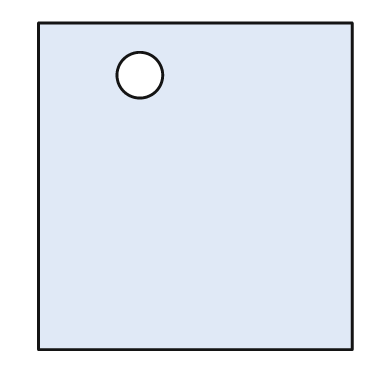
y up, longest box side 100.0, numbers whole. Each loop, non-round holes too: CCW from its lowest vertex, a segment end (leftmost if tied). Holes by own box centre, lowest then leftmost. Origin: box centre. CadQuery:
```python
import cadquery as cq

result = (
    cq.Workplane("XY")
    .moveTo(-48.0, -50.0)
    .lineTo(48.0, -50.0)
    .lineTo(48.0, 50.0)
    .lineTo(-48.0, 50.0)
    .close()
    .moveTo(-17.0, 34.0)
    .circle(7.0)
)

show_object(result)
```